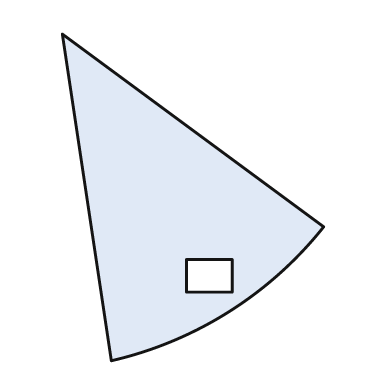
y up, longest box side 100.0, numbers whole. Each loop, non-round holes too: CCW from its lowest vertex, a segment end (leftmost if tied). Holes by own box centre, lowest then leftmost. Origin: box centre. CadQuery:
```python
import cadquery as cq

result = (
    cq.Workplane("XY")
    .moveTo(-25.0, -50.0)
    .threePointArc((11.0, -35.0), (40.0, -9.0))
    .lineTo(-40.0, 50.0)
    .close()
    .moveTo(-2.0, -29.0)
    .lineTo(12.0, -29.0)
    .lineTo(12.0, -19.0)
    .lineTo(-2.0, -19.0)
    .close()
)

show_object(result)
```